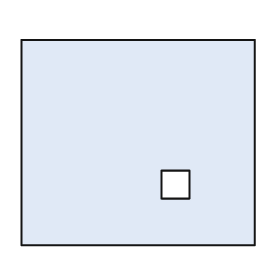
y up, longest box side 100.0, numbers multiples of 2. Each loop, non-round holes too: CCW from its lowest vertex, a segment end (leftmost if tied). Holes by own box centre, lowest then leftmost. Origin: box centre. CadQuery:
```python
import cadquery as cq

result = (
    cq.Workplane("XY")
    .moveTo(-50.0, -44.0)
    .lineTo(50.0, -44.0)
    .lineTo(50.0, 44.0)
    .lineTo(-50.0, 44.0)
    .close()
    .moveTo(10.0, -24.0)
    .lineTo(22.0, -24.0)
    .lineTo(22.0, -12.0)
    .lineTo(10.0, -12.0)
    .close()
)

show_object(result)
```